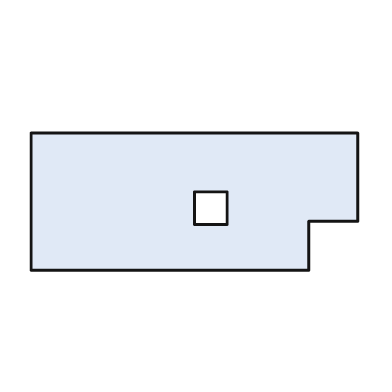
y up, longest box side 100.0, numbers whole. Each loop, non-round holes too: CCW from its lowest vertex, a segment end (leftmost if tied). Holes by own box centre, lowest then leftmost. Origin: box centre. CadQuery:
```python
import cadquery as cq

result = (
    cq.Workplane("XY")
    .moveTo(-50.0, -21.0)
    .lineTo(35.0, -21.0)
    .lineTo(35.0, -6.0)
    .lineTo(50.0, -6.0)
    .lineTo(50.0, 21.0)
    .lineTo(-50.0, 21.0)
    .close()
    .moveTo(0.0, -7.0)
    .lineTo(10.0, -7.0)
    .lineTo(10.0, 3.0)
    .lineTo(0.0, 3.0)
    .close()
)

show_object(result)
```